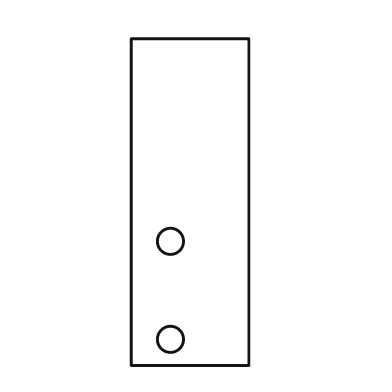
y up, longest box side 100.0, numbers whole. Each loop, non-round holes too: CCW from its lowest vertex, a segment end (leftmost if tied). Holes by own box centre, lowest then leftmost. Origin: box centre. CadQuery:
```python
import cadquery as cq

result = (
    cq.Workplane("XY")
    .moveTo(-18.0, -50.0)
    .lineTo(18.0, -50.0)
    .lineTo(18.0, 50.0)
    .lineTo(-18.0, 50.0)
    .close()
    .moveTo(-6.0, -42.0)
    .circle(4.0)
    .moveTo(-6.0, -12.0)
    .circle(4.0)
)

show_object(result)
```